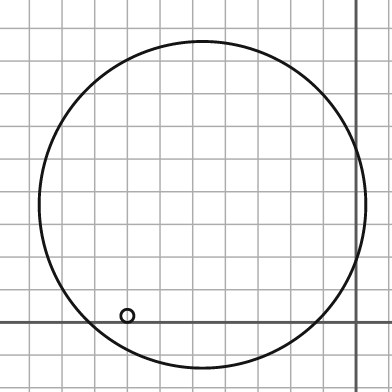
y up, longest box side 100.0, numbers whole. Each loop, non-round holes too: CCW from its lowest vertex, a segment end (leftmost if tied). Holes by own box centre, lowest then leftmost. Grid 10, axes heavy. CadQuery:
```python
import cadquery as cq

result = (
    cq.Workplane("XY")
    .moveTo(-47.0, 36.0)
    .circle(50.0)
    .moveTo(-70.0, 2.0)
    .circle(2.0)
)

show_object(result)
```